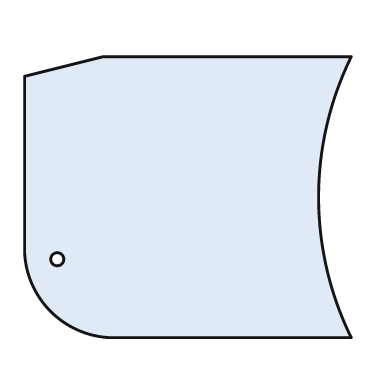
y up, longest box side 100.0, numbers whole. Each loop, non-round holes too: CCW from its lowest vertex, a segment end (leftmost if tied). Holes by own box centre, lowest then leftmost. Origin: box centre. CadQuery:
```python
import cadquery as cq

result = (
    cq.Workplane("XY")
    .moveTo(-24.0, -43.0)
    .lineTo(50.0, -43.0)
    .threePointArc((40.0, 0.0), (50.0, 43.0))
    .lineTo(-26.0, 43.0)
    .lineTo(-50.0, 37.0)
    .lineTo(-50.0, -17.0)
    .threePointArc((-42.0, -35.0), (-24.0, -43.0))
    .close()
    .moveTo(-40.0, -19.0)
    .circle(2.0)
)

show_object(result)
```